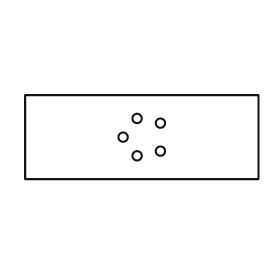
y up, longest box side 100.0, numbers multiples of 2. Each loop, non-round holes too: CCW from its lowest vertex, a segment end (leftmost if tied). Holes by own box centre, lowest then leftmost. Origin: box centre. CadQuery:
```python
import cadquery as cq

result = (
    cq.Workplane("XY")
    .moveTo(-50.0, -18.0)
    .lineTo(50.0, -18.0)
    .lineTo(50.0, 18.0)
    .lineTo(-50.0, 18.0)
    .close()
    .moveTo(-2.0, -8.0)
    .circle(2.0)
    .moveTo(8.0, -6.0)
    .circle(2.0)
    .moveTo(-8.0, 0.0)
    .circle(2.0)
    .moveTo(8.0, 6.0)
    .circle(2.0)
    .moveTo(-2.0, 8.0)
    .circle(2.0)
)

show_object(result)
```